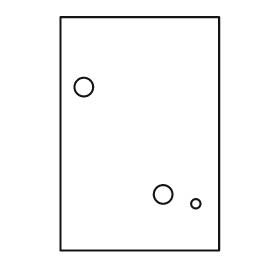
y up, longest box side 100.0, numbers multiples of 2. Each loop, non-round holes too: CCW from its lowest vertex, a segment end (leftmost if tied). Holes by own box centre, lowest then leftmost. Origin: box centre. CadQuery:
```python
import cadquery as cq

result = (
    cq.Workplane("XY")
    .moveTo(-34.0, -50.0)
    .lineTo(34.0, -50.0)
    .lineTo(34.0, 50.0)
    .lineTo(-34.0, 50.0)
    .close()
    .moveTo(24.0, -30.0)
    .circle(2.0)
    .moveTo(10.0, -26.0)
    .circle(4.0)
    .moveTo(-24.0, 20.0)
    .circle(4.0)
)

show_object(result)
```